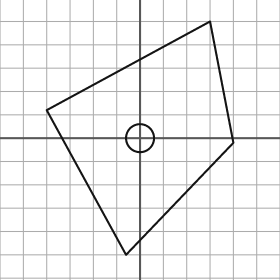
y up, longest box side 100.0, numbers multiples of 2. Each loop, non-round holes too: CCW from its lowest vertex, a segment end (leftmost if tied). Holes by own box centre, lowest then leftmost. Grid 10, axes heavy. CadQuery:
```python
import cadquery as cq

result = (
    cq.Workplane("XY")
    .moveTo(-6.0, -50.0)
    .lineTo(40.0, -2.0)
    .lineTo(30.0, 50.0)
    .lineTo(-40.0, 12.0)
    .close()
    .moveTo(0.0, 0.0)
    .circle(6.0)
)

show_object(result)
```